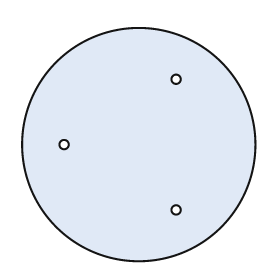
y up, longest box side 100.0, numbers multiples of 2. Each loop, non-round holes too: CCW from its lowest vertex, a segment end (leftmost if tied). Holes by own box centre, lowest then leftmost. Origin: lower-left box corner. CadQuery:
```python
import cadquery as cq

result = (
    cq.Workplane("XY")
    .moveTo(50.0, 50.0)
    .circle(50.0)
    .moveTo(66.0, 22.0)
    .circle(2.0)
    .moveTo(18.0, 50.0)
    .circle(2.0)
    .moveTo(66.0, 78.0)
    .circle(2.0)
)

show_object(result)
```